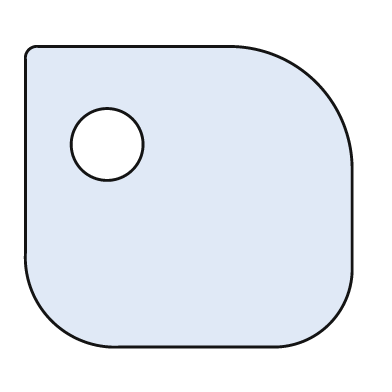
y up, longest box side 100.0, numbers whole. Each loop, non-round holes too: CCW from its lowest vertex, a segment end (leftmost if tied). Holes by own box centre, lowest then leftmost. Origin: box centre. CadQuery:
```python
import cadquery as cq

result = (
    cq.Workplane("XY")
    .moveTo(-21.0, -46.0)
    .lineTo(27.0, -46.0)
    .threePointArc((43.0, -39.0), (50.0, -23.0))
    .lineTo(50.0, 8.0)
    .threePointArc((39.0, 35.0), (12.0, 46.0))
    .lineTo(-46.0, 46.0)
    .threePointArc((-49.0, 45.0), (-50.0, 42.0))
    .lineTo(-50.0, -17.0)
    .threePointArc((-42.0, -38.0), (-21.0, -46.0))
    .close()
    .moveTo(-25.0, 16.0)
    .circle(11.0)
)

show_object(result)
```